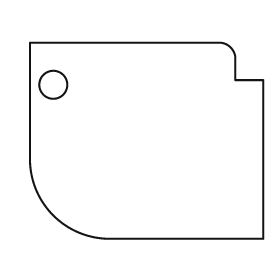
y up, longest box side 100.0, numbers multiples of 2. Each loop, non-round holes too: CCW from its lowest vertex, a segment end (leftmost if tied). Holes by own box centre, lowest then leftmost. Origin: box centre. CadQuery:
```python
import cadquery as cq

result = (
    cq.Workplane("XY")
    .moveTo(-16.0, -42.0)
    .lineTo(50.0, -42.0)
    .lineTo(50.0, 26.0)
    .lineTo(38.0, 26.0)
    .lineTo(38.0, 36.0)
    .threePointArc((36.0, 40.0), (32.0, 42.0))
    .lineTo(-50.0, 42.0)
    .lineTo(-50.0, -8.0)
    .threePointArc((-40.0, -32.0), (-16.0, -42.0))
    .close()
    .moveTo(-40.0, 24.0)
    .circle(6.0)
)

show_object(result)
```